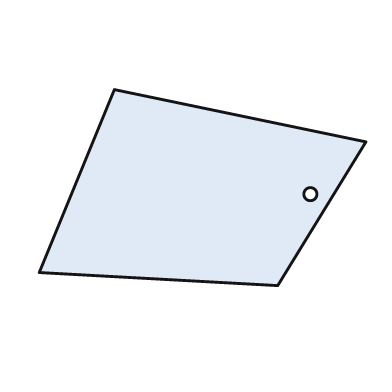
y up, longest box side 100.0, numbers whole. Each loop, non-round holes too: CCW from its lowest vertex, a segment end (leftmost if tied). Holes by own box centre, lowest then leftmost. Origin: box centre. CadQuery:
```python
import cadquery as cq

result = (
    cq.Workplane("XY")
    .moveTo(23.0, -30.0)
    .lineTo(50.0, 14.0)
    .lineTo(-27.0, 30.0)
    .lineTo(-50.0, -26.0)
    .close()
    .moveTo(33.0, -2.0)
    .circle(2.0)
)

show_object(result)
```